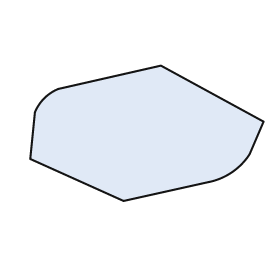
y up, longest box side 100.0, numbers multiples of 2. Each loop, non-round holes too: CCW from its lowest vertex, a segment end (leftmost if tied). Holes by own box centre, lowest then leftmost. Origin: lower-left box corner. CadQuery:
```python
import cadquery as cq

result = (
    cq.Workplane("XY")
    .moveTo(40.0, 0.0)
    .lineTo(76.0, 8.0)
    .threePointArc((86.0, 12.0), (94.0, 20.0))
    .lineTo(100.0, 34.0)
    .lineTo(56.0, 58.0)
    .lineTo(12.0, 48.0)
    .threePointArc((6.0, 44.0), (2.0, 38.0))
    .lineTo(0.0, 18.0)
    .close()
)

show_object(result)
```